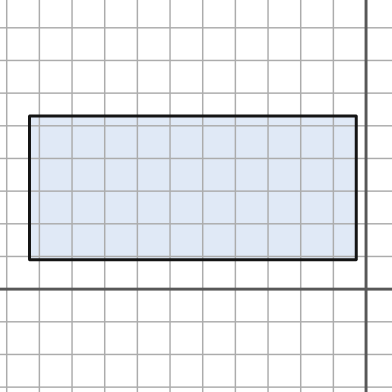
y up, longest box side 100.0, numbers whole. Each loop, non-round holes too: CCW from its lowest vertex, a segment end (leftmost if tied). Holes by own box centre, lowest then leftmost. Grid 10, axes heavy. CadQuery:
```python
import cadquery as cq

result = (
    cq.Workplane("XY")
    .moveTo(-103.0, 9.0)
    .lineTo(-3.0, 9.0)
    .lineTo(-3.0, 53.0)
    .lineTo(-103.0, 53.0)
    .close()
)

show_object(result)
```